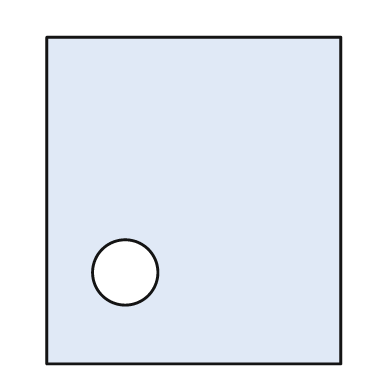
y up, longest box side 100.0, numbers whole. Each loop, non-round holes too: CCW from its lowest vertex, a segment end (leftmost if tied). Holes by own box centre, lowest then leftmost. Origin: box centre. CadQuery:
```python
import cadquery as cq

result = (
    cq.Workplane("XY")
    .moveTo(-45.0, -50.0)
    .lineTo(45.0, -50.0)
    .lineTo(45.0, 50.0)
    .lineTo(-45.0, 50.0)
    .close()
    .moveTo(-21.0, -22.0)
    .circle(10.0)
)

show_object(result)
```